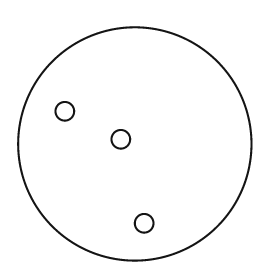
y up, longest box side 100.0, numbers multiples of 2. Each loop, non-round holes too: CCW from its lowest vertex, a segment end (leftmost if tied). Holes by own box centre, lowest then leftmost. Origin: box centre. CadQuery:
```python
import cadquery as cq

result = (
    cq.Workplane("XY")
    .moveTo(0.0, 0.0)
    .circle(50.0)
    .moveTo(4.0, -34.0)
    .circle(4.0)
    .moveTo(-6.0, 2.0)
    .circle(4.0)
    .moveTo(-30.0, 14.0)
    .circle(4.0)
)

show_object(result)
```